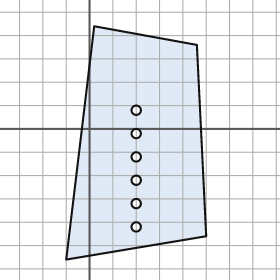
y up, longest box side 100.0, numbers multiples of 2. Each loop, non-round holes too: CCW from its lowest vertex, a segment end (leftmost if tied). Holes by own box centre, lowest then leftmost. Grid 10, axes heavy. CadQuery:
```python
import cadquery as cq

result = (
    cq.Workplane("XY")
    .moveTo(-10.0, -56.0)
    .lineTo(50.0, -46.0)
    .lineTo(46.0, 36.0)
    .lineTo(2.0, 44.0)
    .close()
    .moveTo(20.0, -42.0)
    .circle(2.0)
    .moveTo(20.0, -32.0)
    .circle(2.0)
    .moveTo(20.0, -22.0)
    .circle(2.0)
    .moveTo(20.0, -12.0)
    .circle(2.0)
    .moveTo(20.0, -2.0)
    .circle(2.0)
    .moveTo(20.0, 8.0)
    .circle(2.0)
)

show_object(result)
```